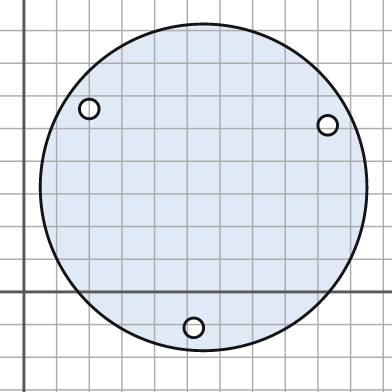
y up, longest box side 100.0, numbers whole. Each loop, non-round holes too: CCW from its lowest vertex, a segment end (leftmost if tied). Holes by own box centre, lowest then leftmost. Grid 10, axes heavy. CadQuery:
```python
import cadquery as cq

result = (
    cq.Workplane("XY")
    .moveTo(55.0, 32.0)
    .circle(50.0)
    .moveTo(52.0, -11.0)
    .circle(3.0)
    .moveTo(93.0, 51.0)
    .circle(3.0)
    .moveTo(20.0, 56.0)
    .circle(3.0)
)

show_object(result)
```